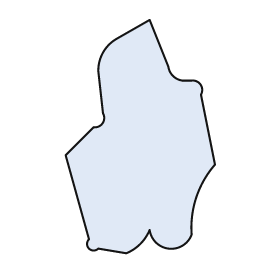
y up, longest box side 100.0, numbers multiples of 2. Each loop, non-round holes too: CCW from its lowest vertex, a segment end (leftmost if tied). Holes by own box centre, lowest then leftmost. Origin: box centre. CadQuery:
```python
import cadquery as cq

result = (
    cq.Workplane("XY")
    .moveTo(-6.0, -50.0)
    .threePointArc((0.0, -46.0), (4.0, -40.0))
    .threePointArc((12.0, -48.0), (22.0, -42.0))
    .threePointArc((24.0, -26.0), (32.0, -12.0))
    .lineTo(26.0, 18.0)
    .threePointArc((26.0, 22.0), (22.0, 24.0))
    .lineTo(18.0, 24.0)
    .threePointArc((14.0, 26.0), (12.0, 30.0))
    .lineTo(4.0, 50.0)
    .lineTo(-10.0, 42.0)
    .threePointArc((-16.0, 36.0), (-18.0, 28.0))
    .lineTo(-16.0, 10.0)
    .threePointArc((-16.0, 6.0), (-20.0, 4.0))
    .lineTo(-32.0, -8.0)
    .lineTo(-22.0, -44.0)
    .threePointArc((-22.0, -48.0), (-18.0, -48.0))
    .close()
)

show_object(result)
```